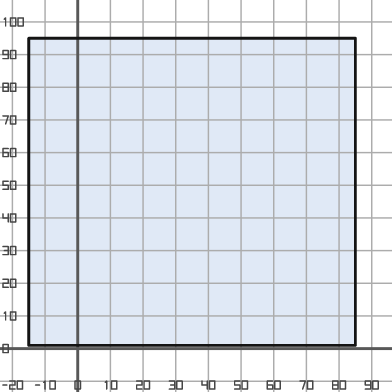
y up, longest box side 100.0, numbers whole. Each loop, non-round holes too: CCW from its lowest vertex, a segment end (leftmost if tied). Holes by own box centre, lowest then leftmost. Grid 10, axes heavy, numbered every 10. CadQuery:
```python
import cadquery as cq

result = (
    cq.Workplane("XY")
    .moveTo(-15.0, 1.0)
    .lineTo(85.0, 1.0)
    .lineTo(85.0, 95.0)
    .lineTo(-15.0, 95.0)
    .close()
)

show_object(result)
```